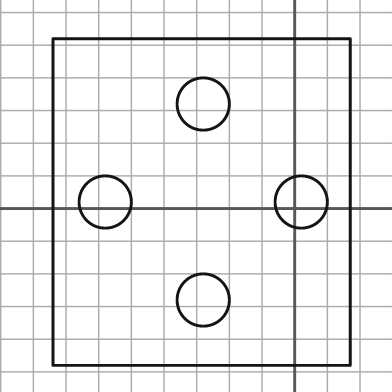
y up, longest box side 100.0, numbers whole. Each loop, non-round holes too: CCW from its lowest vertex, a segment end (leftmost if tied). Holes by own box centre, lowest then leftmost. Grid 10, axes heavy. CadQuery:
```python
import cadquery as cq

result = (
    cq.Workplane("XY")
    .moveTo(-74.0, -48.0)
    .lineTo(17.0, -48.0)
    .lineTo(17.0, 52.0)
    .lineTo(-74.0, 52.0)
    .close()
    .moveTo(-28.0, -28.0)
    .circle(8.0)
    .moveTo(-58.0, 2.0)
    .circle(8.0)
    .moveTo(2.0, 2.0)
    .circle(8.0)
    .moveTo(-28.0, 32.0)
    .circle(8.0)
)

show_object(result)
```